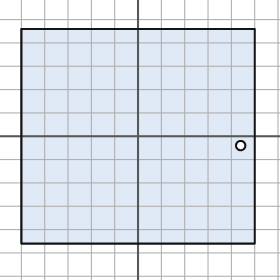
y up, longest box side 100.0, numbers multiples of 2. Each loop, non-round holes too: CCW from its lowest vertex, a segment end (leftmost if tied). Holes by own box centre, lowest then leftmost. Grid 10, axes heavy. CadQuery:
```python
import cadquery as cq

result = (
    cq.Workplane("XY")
    .moveTo(-50.0, -46.0)
    .lineTo(50.0, -46.0)
    .lineTo(50.0, 46.0)
    .lineTo(-50.0, 46.0)
    .close()
    .moveTo(44.0, -4.0)
    .circle(2.0)
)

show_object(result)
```